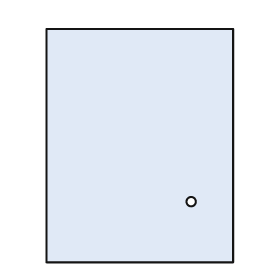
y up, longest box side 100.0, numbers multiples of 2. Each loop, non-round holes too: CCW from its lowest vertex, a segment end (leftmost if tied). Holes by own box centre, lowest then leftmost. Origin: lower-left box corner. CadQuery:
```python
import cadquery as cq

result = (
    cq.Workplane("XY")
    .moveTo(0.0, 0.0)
    .lineTo(80.0, 0.0)
    .lineTo(80.0, 100.0)
    .lineTo(0.0, 100.0)
    .close()
    .moveTo(62.0, 26.0)
    .circle(2.0)
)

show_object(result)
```